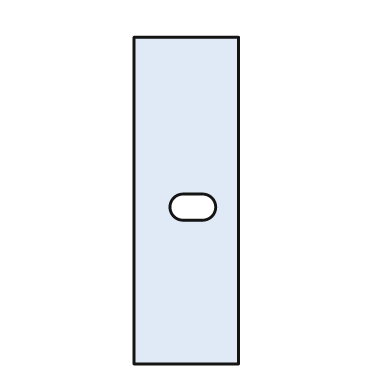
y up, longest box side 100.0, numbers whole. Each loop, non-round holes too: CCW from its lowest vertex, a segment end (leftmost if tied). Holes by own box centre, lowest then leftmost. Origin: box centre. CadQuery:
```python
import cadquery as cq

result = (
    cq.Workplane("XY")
    .moveTo(-16.0, -50.0)
    .lineTo(16.0, -50.0)
    .lineTo(16.0, 50.0)
    .lineTo(-16.0, 50.0)
    .close()
    .moveTo(-1.0, -6.0)
    .lineTo(5.0, -6.0)
    .threePointArc((9.0, -2.0), (5.0, 2.0))
    .lineTo(-1.0, 2.0)
    .threePointArc((-5.0, -2.0), (-1.0, -6.0))
    .close()
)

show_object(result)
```